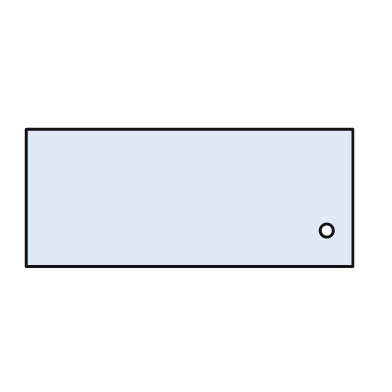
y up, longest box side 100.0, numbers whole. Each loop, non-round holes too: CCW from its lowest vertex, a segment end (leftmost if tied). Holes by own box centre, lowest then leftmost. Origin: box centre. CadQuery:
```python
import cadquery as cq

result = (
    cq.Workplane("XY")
    .moveTo(-50.0, -21.0)
    .lineTo(50.0, -21.0)
    .lineTo(50.0, 21.0)
    .lineTo(-50.0, 21.0)
    .close()
    .moveTo(42.0, -10.0)
    .circle(2.0)
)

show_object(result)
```